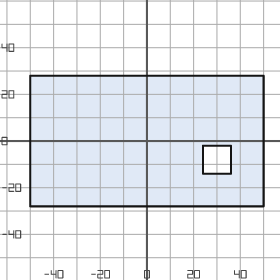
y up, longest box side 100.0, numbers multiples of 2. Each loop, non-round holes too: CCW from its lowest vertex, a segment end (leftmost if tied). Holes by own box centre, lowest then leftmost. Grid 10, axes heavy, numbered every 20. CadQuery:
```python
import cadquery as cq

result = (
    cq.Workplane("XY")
    .moveTo(-50.0, -28.0)
    .lineTo(50.0, -28.0)
    .lineTo(50.0, 28.0)
    .lineTo(-50.0, 28.0)
    .close()
    .moveTo(24.0, -14.0)
    .lineTo(36.0, -14.0)
    .lineTo(36.0, -2.0)
    .lineTo(24.0, -2.0)
    .close()
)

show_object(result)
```